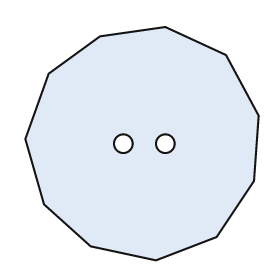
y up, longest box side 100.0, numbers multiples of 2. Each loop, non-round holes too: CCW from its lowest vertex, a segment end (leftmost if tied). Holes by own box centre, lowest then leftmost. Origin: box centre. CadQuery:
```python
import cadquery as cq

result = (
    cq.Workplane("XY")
    .moveTo(6.0, -50.0)
    .lineTo(32.0, -40.0)
    .lineTo(48.0, -16.0)
    .lineTo(50.0, 12.0)
    .lineTo(36.0, 38.0)
    .lineTo(10.0, 50.0)
    .lineTo(-18.0, 46.0)
    .lineTo(-40.0, 30.0)
    .lineTo(-50.0, 2.0)
    .lineTo(-42.0, -26.0)
    .lineTo(-22.0, -44.0)
    .close()
    .moveTo(-8.0, 0.0)
    .circle(4.0)
    .moveTo(10.0, 0.0)
    .circle(4.0)
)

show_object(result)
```